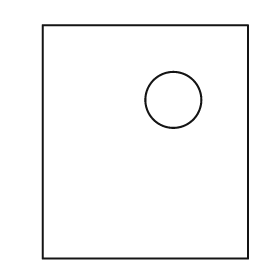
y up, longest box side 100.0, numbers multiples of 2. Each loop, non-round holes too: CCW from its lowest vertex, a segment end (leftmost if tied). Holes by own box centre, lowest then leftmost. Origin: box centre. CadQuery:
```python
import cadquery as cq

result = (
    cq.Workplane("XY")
    .moveTo(-44.0, -50.0)
    .lineTo(44.0, -50.0)
    .lineTo(44.0, 50.0)
    .lineTo(-44.0, 50.0)
    .close()
    .moveTo(12.0, 18.0)
    .circle(12.0)
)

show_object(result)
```